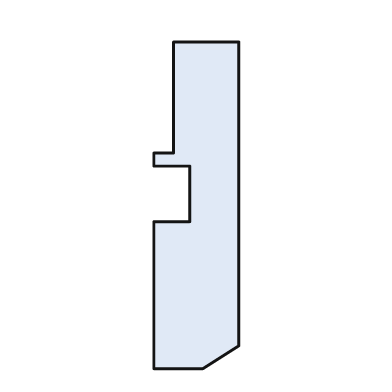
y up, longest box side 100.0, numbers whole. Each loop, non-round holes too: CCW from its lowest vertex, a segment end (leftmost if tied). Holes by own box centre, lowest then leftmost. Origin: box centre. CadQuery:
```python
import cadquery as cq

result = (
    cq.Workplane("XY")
    .moveTo(-13.0, -50.0)
    .lineTo(2.0, -50.0)
    .lineTo(13.0, -43.0)
    .lineTo(13.0, 50.0)
    .lineTo(-7.0, 50.0)
    .lineTo(-7.0, 16.0)
    .lineTo(-13.0, 16.0)
    .lineTo(-13.0, 12.0)
    .lineTo(-2.0, 12.0)
    .lineTo(-2.0, -5.0)
    .lineTo(-13.0, -5.0)
    .close()
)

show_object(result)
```